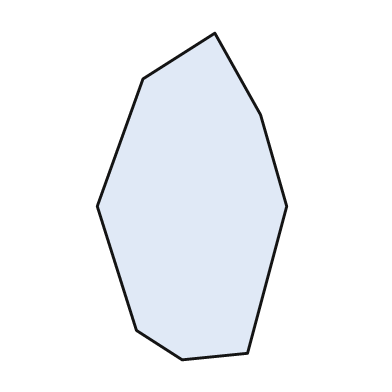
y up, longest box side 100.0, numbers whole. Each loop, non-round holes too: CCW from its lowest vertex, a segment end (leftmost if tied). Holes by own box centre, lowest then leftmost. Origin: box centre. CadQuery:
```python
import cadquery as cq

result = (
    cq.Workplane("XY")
    .moveTo(-3.0, -50.0)
    .lineTo(17.0, -48.0)
    .lineTo(29.0, -3.0)
    .lineTo(21.0, 25.0)
    .lineTo(7.0, 50.0)
    .lineTo(-15.0, 36.0)
    .lineTo(-29.0, -3.0)
    .lineTo(-17.0, -41.0)
    .close()
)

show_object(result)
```